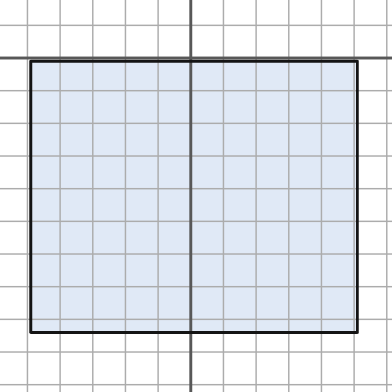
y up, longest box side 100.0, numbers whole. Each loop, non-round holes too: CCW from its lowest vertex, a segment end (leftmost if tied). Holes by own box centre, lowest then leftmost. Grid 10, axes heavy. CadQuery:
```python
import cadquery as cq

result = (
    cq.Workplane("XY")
    .moveTo(-49.0, -84.0)
    .lineTo(51.0, -84.0)
    .lineTo(51.0, -1.0)
    .lineTo(-49.0, -1.0)
    .close()
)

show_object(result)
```